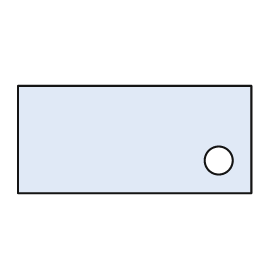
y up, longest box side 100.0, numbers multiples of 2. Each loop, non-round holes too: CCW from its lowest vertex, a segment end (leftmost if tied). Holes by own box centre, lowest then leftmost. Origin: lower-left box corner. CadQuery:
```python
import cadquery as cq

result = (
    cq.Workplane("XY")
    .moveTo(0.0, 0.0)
    .lineTo(100.0, 0.0)
    .lineTo(100.0, 46.0)
    .lineTo(0.0, 46.0)
    .close()
    .moveTo(86.0, 14.0)
    .circle(6.0)
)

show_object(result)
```